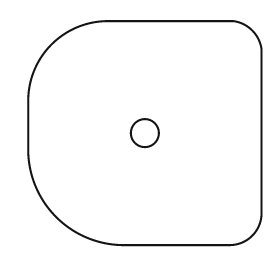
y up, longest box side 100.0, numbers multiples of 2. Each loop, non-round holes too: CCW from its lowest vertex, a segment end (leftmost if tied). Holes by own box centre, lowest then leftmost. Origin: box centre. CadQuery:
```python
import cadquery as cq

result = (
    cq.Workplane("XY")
    .moveTo(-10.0, -48.0)
    .lineTo(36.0, -48.0)
    .threePointArc((46.0, -44.0), (50.0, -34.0))
    .lineTo(50.0, 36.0)
    .threePointArc((46.0, 44.0), (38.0, 48.0))
    .lineTo(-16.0, 48.0)
    .threePointArc((-40.0, 38.0), (-50.0, 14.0))
    .lineTo(-50.0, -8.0)
    .threePointArc((-38.0, -36.0), (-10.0, -48.0))
    .close()
    .moveTo(0.0, 0.0)
    .circle(6.0)
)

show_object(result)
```